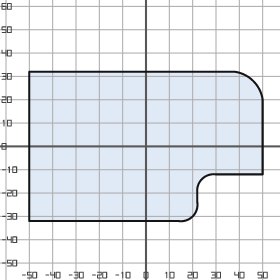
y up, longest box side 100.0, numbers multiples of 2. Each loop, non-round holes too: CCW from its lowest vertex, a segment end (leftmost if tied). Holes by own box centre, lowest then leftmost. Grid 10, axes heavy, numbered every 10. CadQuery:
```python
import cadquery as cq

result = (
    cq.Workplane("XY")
    .moveTo(-50.0, -32.0)
    .lineTo(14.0, -32.0)
    .threePointArc((20.0, -30.0), (22.0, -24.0))
    .lineTo(22.0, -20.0)
    .threePointArc((24.0, -14.0), (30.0, -12.0))
    .lineTo(50.0, -12.0)
    .lineTo(50.0, 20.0)
    .threePointArc((46.0, 28.0), (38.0, 32.0))
    .lineTo(-50.0, 32.0)
    .close()
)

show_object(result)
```